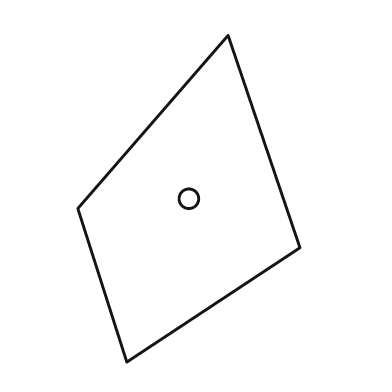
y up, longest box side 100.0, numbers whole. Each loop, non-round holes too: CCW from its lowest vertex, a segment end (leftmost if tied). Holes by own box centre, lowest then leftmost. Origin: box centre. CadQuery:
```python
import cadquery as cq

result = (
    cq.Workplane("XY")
    .moveTo(-19.0, -50.0)
    .lineTo(34.0, -15.0)
    .lineTo(12.0, 50.0)
    .lineTo(-34.0, -3.0)
    .close()
    .moveTo(0.0, 0.0)
    .circle(3.0)
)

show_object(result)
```